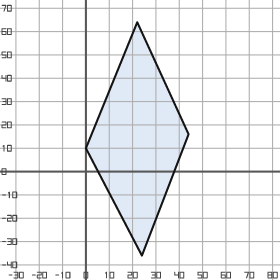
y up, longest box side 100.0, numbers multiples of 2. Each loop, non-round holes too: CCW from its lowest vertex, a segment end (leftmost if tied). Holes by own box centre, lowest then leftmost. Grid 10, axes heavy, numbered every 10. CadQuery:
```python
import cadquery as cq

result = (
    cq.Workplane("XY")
    .moveTo(24.0, -36.0)
    .lineTo(44.0, 16.0)
    .lineTo(22.0, 64.0)
    .lineTo(0.0, 10.0)
    .close()
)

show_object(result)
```